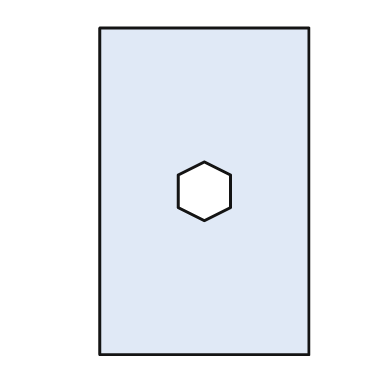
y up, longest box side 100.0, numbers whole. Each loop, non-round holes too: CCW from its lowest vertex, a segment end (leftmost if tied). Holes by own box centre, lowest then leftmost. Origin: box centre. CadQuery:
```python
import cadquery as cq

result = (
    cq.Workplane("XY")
    .moveTo(-32.0, -50.0)
    .lineTo(32.0, -50.0)
    .lineTo(32.0, 50.0)
    .lineTo(-32.0, 50.0)
    .close()
    .moveTo(0.0, -9.0)
    .lineTo(8.0, -5.0)
    .lineTo(8.0, 5.0)
    .lineTo(0.0, 9.0)
    .lineTo(-8.0, 5.0)
    .lineTo(-8.0, -5.0)
    .close()
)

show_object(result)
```